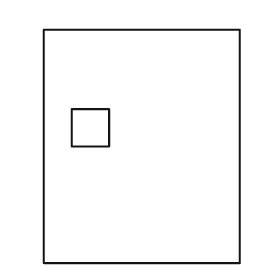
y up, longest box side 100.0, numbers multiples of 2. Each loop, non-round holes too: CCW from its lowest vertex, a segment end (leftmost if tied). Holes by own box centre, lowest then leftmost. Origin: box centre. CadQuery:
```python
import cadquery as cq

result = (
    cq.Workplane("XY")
    .moveTo(-42.0, -50.0)
    .lineTo(42.0, -50.0)
    .lineTo(42.0, 50.0)
    .lineTo(-42.0, 50.0)
    .close()
    .moveTo(-30.0, 0.0)
    .lineTo(-14.0, 0.0)
    .lineTo(-14.0, 16.0)
    .lineTo(-30.0, 16.0)
    .close()
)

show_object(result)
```